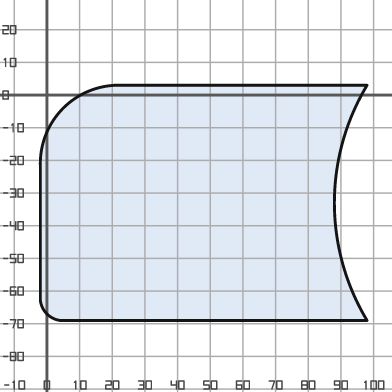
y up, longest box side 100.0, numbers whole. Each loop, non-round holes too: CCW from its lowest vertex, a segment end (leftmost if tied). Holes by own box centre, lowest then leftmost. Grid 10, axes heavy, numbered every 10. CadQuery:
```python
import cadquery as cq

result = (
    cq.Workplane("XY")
    .moveTo(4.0, -69.0)
    .lineTo(98.0, -69.0)
    .threePointArc((88.0, -33.0), (98.0, 3.0))
    .lineTo(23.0, 3.0)
    .threePointArc((5.0, -4.0), (-2.0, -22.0))
    .lineTo(-2.0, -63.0)
    .threePointArc((0.0, -67.0), (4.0, -69.0))
    .close()
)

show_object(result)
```